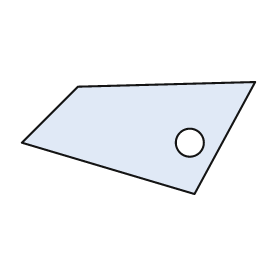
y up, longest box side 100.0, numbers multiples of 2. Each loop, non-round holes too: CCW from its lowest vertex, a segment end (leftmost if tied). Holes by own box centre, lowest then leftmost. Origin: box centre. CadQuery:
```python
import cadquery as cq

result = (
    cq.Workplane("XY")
    .moveTo(24.0, -24.0)
    .lineTo(50.0, 24.0)
    .lineTo(-26.0, 22.0)
    .lineTo(-50.0, -2.0)
    .close()
    .moveTo(22.0, -2.0)
    .circle(6.0)
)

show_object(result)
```